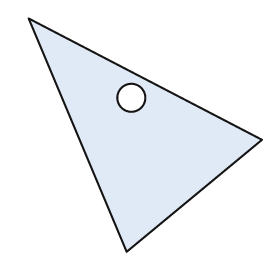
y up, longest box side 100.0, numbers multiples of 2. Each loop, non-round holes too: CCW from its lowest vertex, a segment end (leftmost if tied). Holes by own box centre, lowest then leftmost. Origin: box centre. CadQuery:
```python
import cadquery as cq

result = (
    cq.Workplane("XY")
    .moveTo(-8.0, -50.0)
    .lineTo(50.0, -2.0)
    .lineTo(-50.0, 50.0)
    .close()
    .moveTo(-6.0, 16.0)
    .circle(6.0)
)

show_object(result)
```